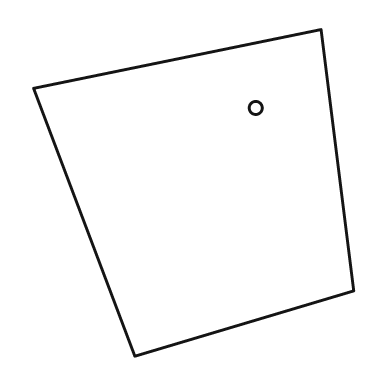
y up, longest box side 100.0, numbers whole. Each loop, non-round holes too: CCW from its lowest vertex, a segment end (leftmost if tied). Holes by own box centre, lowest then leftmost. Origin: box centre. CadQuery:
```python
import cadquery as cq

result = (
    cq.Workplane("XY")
    .moveTo(-18.0, -50.0)
    .lineTo(49.0, -30.0)
    .lineTo(39.0, 50.0)
    .lineTo(-49.0, 32.0)
    .close()
    .moveTo(19.0, 26.0)
    .circle(2.0)
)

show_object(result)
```